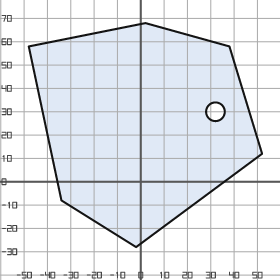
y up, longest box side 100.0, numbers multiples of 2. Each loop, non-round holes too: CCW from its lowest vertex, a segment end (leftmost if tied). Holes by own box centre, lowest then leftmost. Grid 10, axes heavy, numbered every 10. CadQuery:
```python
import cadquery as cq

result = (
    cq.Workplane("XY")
    .moveTo(-2.0, -28.0)
    .lineTo(52.0, 12.0)
    .lineTo(38.0, 58.0)
    .lineTo(2.0, 68.0)
    .lineTo(-48.0, 58.0)
    .lineTo(-34.0, -8.0)
    .close()
    .moveTo(32.0, 30.0)
    .circle(4.0)
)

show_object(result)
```